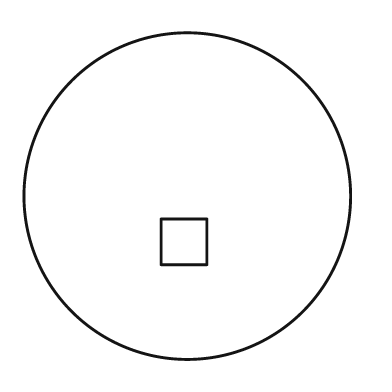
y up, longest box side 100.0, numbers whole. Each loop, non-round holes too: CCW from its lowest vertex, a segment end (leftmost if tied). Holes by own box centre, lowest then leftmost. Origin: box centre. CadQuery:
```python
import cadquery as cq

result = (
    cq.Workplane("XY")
    .moveTo(0.0, 0.0)
    .circle(50.0)
    .moveTo(-8.0, -21.0)
    .lineTo(6.0, -21.0)
    .lineTo(6.0, -7.0)
    .lineTo(-8.0, -7.0)
    .close()
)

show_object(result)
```